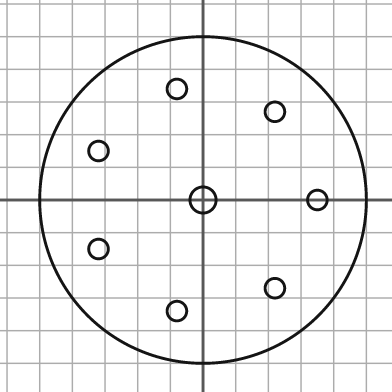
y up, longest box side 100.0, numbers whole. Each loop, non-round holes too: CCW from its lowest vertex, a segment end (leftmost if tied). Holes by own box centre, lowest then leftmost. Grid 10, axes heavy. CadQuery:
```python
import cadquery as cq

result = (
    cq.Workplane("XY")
    .moveTo(0.0, 0.0)
    .circle(50.0)
    .moveTo(-8.0, -34.0)
    .circle(3.0)
    .moveTo(22.0, -27.0)
    .circle(3.0)
    .moveTo(-32.0, -15.0)
    .circle(3.0)
    .moveTo(0.0, 0.0)
    .circle(4.0)
    .moveTo(35.0, 0.0)
    .circle(3.0)
    .moveTo(-32.0, 15.0)
    .circle(3.0)
    .moveTo(22.0, 27.0)
    .circle(3.0)
    .moveTo(-8.0, 34.0)
    .circle(3.0)
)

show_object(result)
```